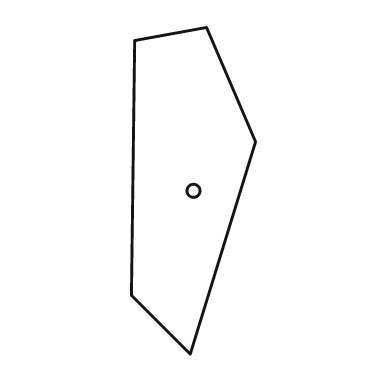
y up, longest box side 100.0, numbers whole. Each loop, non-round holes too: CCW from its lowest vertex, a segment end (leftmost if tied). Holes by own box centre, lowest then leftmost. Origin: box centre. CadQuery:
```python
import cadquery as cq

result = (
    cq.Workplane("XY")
    .moveTo(-1.0, -50.0)
    .lineTo(19.0, 15.0)
    .lineTo(4.0, 50.0)
    .lineTo(-18.0, 46.0)
    .lineTo(-19.0, -32.0)
    .close()
    .moveTo(0.0, 0.0)
    .circle(2.0)
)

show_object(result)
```